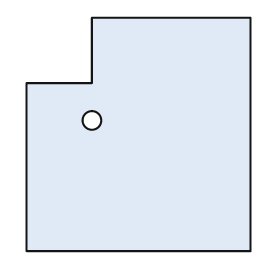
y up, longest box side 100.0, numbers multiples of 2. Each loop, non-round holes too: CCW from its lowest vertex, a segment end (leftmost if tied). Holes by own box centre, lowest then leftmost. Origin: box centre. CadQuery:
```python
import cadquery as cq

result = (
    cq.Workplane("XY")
    .moveTo(-48.0, -50.0)
    .lineTo(48.0, -50.0)
    .lineTo(48.0, 50.0)
    .lineTo(-20.0, 50.0)
    .lineTo(-20.0, 22.0)
    .lineTo(-48.0, 22.0)
    .close()
    .moveTo(-20.0, 6.0)
    .circle(4.0)
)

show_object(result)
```